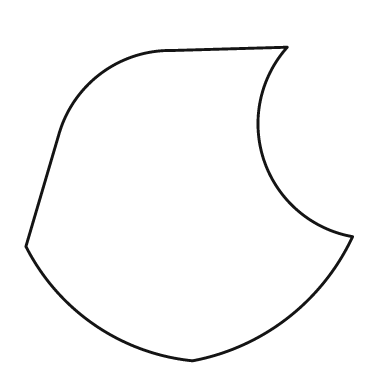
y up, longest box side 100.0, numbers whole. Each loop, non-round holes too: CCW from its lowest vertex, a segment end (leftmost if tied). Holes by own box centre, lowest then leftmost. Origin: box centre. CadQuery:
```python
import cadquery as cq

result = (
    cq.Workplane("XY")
    .moveTo(1.0, -48.0)
    .threePointArc((30.0, -35.0), (50.0, -10.0))
    .threePointArc((23.0, 13.0), (30.0, 48.0))
    .lineTo(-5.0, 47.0)
    .threePointArc((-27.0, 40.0), (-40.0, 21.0))
    .lineTo(-50.0, -13.0)
    .threePointArc((-29.0, -37.0), (1.0, -48.0))
    .close()
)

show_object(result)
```